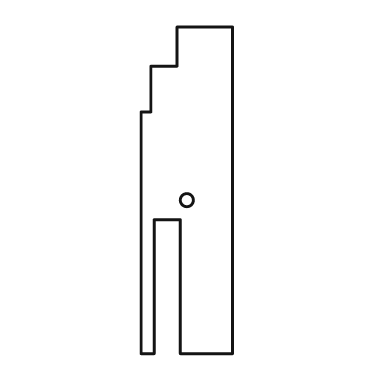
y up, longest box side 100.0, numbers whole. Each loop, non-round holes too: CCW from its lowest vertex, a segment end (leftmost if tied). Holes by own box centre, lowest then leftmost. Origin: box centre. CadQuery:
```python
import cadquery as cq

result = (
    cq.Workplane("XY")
    .moveTo(-14.0, -50.0)
    .lineTo(-10.0, -50.0)
    .lineTo(-10.0, -9.0)
    .lineTo(-2.0, -9.0)
    .lineTo(-2.0, -50.0)
    .lineTo(14.0, -50.0)
    .lineTo(14.0, 50.0)
    .lineTo(-3.0, 50.0)
    .lineTo(-3.0, 38.0)
    .lineTo(-11.0, 38.0)
    .lineTo(-11.0, 24.0)
    .lineTo(-14.0, 24.0)
    .close()
    .moveTo(0.0, -3.0)
    .circle(2.0)
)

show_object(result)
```